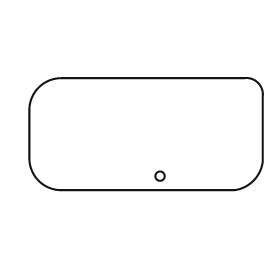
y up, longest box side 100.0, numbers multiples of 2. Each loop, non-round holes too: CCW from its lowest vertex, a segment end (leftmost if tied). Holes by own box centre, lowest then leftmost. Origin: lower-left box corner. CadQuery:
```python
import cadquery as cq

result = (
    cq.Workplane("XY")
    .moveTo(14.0, 0.0)
    .lineTo(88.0, 0.0)
    .threePointArc((96.0, 4.0), (100.0, 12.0))
    .lineTo(100.0, 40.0)
    .threePointArc((98.0, 46.0), (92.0, 48.0))
    .lineTo(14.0, 48.0)
    .threePointArc((4.0, 44.0), (0.0, 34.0))
    .lineTo(0.0, 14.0)
    .threePointArc((4.0, 4.0), (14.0, 0.0))
    .close()
    .moveTo(56.0, 6.0)
    .circle(2.0)
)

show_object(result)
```